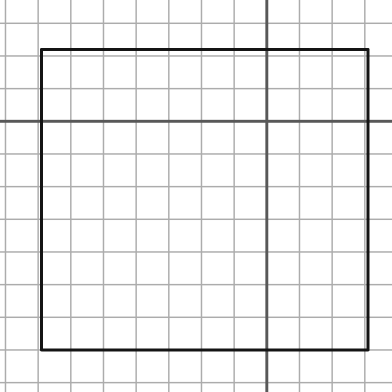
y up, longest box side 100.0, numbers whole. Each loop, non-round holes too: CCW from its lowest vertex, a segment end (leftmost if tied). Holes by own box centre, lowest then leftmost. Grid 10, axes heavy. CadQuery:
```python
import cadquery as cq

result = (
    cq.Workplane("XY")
    .moveTo(-69.0, -70.0)
    .lineTo(31.0, -70.0)
    .lineTo(31.0, 22.0)
    .lineTo(-69.0, 22.0)
    .close()
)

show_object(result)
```